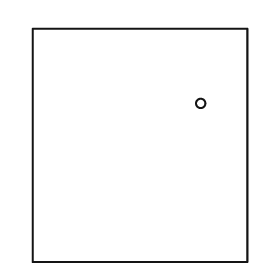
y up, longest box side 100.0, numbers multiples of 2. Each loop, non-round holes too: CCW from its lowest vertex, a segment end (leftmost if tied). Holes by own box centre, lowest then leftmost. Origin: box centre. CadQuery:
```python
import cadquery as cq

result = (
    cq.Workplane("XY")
    .moveTo(-46.0, -50.0)
    .lineTo(46.0, -50.0)
    .lineTo(46.0, 50.0)
    .lineTo(-46.0, 50.0)
    .close()
    .moveTo(26.0, 18.0)
    .circle(2.0)
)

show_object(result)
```